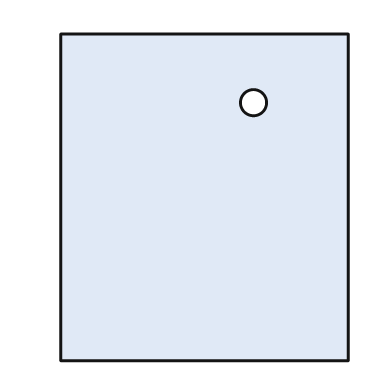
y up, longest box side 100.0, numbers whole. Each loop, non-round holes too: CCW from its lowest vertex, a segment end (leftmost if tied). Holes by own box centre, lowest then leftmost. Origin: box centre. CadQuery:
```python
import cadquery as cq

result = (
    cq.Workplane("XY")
    .moveTo(-44.0, -50.0)
    .lineTo(44.0, -50.0)
    .lineTo(44.0, 50.0)
    .lineTo(-44.0, 50.0)
    .close()
    .moveTo(15.0, 29.0)
    .circle(4.0)
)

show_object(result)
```